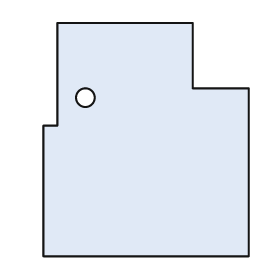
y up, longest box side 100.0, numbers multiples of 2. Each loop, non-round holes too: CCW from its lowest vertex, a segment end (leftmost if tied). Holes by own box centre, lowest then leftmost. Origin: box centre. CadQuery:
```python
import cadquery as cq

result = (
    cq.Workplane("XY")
    .moveTo(-44.0, -50.0)
    .lineTo(44.0, -50.0)
    .lineTo(44.0, 22.0)
    .lineTo(20.0, 22.0)
    .lineTo(20.0, 50.0)
    .lineTo(-38.0, 50.0)
    .lineTo(-38.0, 6.0)
    .lineTo(-44.0, 6.0)
    .close()
    .moveTo(-26.0, 18.0)
    .circle(4.0)
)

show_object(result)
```